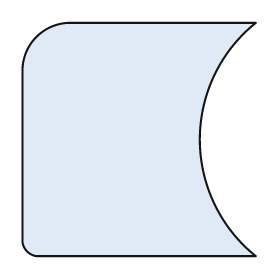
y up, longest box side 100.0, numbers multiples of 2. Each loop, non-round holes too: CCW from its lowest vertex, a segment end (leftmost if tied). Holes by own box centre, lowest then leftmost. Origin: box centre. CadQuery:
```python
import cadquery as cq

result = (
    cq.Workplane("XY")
    .moveTo(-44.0, -50.0)
    .lineTo(50.0, -50.0)
    .threePointArc((26.0, 0.0), (50.0, 50.0))
    .lineTo(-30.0, 50.0)
    .threePointArc((-44.0, 44.0), (-50.0, 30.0))
    .lineTo(-50.0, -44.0)
    .threePointArc((-48.0, -48.0), (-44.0, -50.0))
    .close()
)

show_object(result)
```